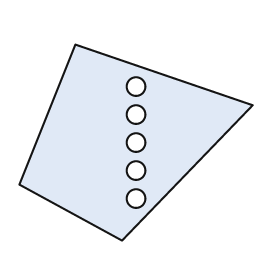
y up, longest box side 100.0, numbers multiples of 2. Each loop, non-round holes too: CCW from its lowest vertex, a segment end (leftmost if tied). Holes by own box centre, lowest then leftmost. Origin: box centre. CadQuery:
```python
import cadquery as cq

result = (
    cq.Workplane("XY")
    .moveTo(-6.0, -42.0)
    .lineTo(50.0, 16.0)
    .lineTo(-26.0, 42.0)
    .lineTo(-50.0, -18.0)
    .close()
    .moveTo(0.0, -24.0)
    .circle(4.0)
    .moveTo(0.0, -12.0)
    .circle(4.0)
    .moveTo(0.0, 0.0)
    .circle(4.0)
    .moveTo(0.0, 12.0)
    .circle(4.0)
    .moveTo(0.0, 24.0)
    .circle(4.0)
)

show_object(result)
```